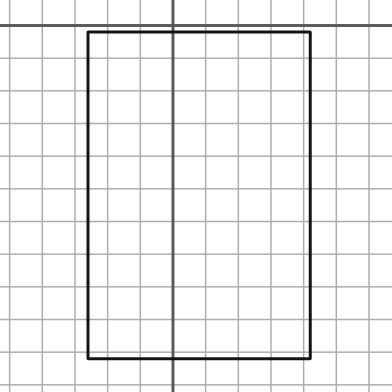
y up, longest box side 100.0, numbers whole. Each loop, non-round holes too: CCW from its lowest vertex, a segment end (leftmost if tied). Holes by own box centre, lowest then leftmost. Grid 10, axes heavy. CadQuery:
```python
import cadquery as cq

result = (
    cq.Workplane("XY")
    .moveTo(-26.0, -102.0)
    .lineTo(42.0, -102.0)
    .lineTo(42.0, -2.0)
    .lineTo(-26.0, -2.0)
    .close()
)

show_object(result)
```